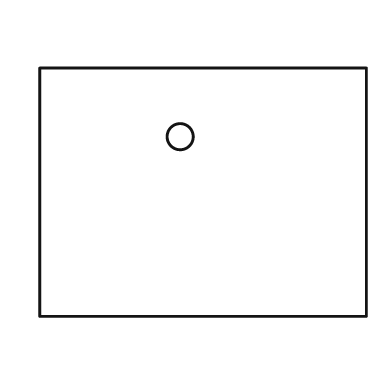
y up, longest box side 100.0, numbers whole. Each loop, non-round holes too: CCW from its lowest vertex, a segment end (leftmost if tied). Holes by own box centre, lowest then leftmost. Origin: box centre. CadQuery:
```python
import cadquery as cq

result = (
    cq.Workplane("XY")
    .moveTo(-50.0, -38.0)
    .lineTo(50.0, -38.0)
    .lineTo(50.0, 38.0)
    .lineTo(-50.0, 38.0)
    .close()
    .moveTo(-7.0, 17.0)
    .circle(4.0)
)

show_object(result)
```